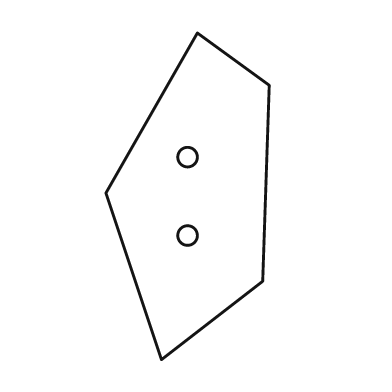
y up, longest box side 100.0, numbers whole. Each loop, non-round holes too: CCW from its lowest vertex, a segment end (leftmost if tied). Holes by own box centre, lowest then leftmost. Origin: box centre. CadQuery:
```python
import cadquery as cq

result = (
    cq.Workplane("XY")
    .moveTo(-8.0, -50.0)
    .lineTo(23.0, -26.0)
    .lineTo(25.0, 34.0)
    .lineTo(3.0, 50.0)
    .lineTo(-25.0, 1.0)
    .close()
    .moveTo(0.0, -12.0)
    .circle(3.0)
    .moveTo(0.0, 12.0)
    .circle(3.0)
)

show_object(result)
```